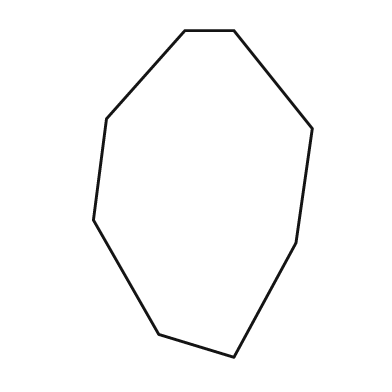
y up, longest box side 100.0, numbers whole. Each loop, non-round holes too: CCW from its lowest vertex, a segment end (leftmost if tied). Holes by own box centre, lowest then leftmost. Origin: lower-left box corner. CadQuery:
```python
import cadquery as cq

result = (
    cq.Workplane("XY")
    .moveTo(43.0, 0.0)
    .lineTo(62.0, 35.0)
    .lineTo(67.0, 70.0)
    .lineTo(43.0, 100.0)
    .lineTo(28.0, 100.0)
    .lineTo(4.0, 73.0)
    .lineTo(0.0, 42.0)
    .lineTo(20.0, 7.0)
    .close()
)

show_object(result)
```